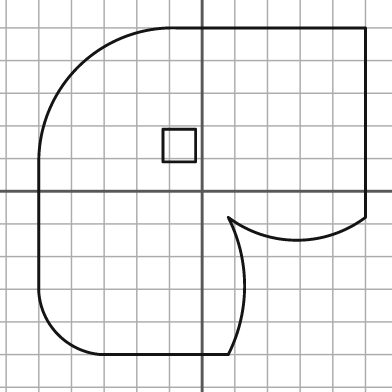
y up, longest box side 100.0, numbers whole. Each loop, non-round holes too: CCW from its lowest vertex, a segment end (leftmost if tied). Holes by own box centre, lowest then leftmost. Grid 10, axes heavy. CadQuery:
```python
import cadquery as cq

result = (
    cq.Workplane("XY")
    .moveTo(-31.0, -50.0)
    .lineTo(8.0, -50.0)
    .threePointArc((13.0, -29.0), (8.0, -8.0))
    .threePointArc((29.0, -15.0), (50.0, -8.0))
    .lineTo(50.0, 50.0)
    .lineTo(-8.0, 50.0)
    .threePointArc((-38.0, 38.0), (-50.0, 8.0))
    .lineTo(-50.0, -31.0)
    .threePointArc((-44.0, -44.0), (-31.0, -50.0))
    .close()
    .moveTo(-12.0, 9.0)
    .lineTo(-2.0, 9.0)
    .lineTo(-2.0, 19.0)
    .lineTo(-12.0, 19.0)
    .close()
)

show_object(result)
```